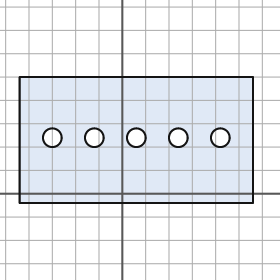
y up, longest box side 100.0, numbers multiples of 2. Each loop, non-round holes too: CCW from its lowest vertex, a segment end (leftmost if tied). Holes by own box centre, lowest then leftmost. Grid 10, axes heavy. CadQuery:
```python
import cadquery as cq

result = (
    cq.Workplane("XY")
    .moveTo(-44.0, -4.0)
    .lineTo(56.0, -4.0)
    .lineTo(56.0, 50.0)
    .lineTo(-44.0, 50.0)
    .close()
    .moveTo(-30.0, 24.0)
    .circle(4.0)
    .moveTo(-12.0, 24.0)
    .circle(4.0)
    .moveTo(6.0, 24.0)
    .circle(4.0)
    .moveTo(24.0, 24.0)
    .circle(4.0)
    .moveTo(42.0, 24.0)
    .circle(4.0)
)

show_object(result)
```